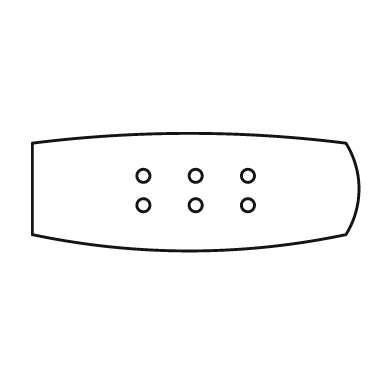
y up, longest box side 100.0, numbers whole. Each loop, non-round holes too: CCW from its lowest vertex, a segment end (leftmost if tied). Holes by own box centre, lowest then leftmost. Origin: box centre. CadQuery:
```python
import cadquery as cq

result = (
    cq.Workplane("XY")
    .moveTo(-50.0, -13.0)
    .threePointArc((-2.0, -18.0), (46.0, -13.0))
    .threePointArc((50.0, 1.0), (46.0, 15.0))
    .threePointArc((-2.0, 18.0), (-50.0, 15.0))
    .close()
    .moveTo(-16.0, -4.0)
    .circle(2.0)
    .moveTo(0.0, -4.0)
    .circle(2.0)
    .moveTo(16.0, -4.0)
    .circle(2.0)
    .moveTo(-16.0, 5.0)
    .circle(2.0)
    .moveTo(0.0, 5.0)
    .circle(2.0)
    .moveTo(16.0, 5.0)
    .circle(2.0)
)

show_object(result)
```